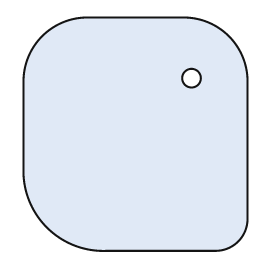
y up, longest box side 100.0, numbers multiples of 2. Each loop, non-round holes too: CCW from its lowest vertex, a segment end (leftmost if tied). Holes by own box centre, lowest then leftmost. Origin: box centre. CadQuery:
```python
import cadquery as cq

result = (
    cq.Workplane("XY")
    .moveTo(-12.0, -50.0)
    .lineTo(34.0, -50.0)
    .threePointArc((44.0, -46.0), (48.0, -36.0))
    .lineTo(48.0, 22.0)
    .threePointArc((40.0, 42.0), (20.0, 50.0))
    .lineTo(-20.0, 50.0)
    .threePointArc((-40.0, 42.0), (-48.0, 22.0))
    .lineTo(-48.0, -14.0)
    .threePointArc((-38.0, -40.0), (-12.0, -50.0))
    .close()
    .moveTo(24.0, 24.0)
    .circle(4.0)
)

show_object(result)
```